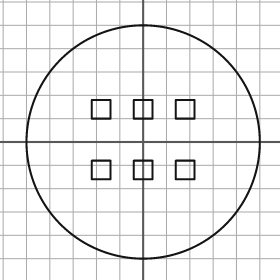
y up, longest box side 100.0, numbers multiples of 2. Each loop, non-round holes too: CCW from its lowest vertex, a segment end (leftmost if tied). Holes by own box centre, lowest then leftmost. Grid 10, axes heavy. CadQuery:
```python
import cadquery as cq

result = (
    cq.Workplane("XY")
    .moveTo(0.0, 0.0)
    .circle(50.0)
    .moveTo(-22.0, -16.0)
    .lineTo(-14.0, -16.0)
    .lineTo(-14.0, -8.0)
    .lineTo(-22.0, -8.0)
    .close()
    .moveTo(-4.0, -16.0)
    .lineTo(4.0, -16.0)
    .lineTo(4.0, -8.0)
    .lineTo(-4.0, -8.0)
    .close()
    .moveTo(14.0, -16.0)
    .lineTo(22.0, -16.0)
    .lineTo(22.0, -8.0)
    .lineTo(14.0, -8.0)
    .close()
    .moveTo(-22.0, 10.0)
    .lineTo(-14.0, 10.0)
    .lineTo(-14.0, 18.0)
    .lineTo(-22.0, 18.0)
    .close()
    .moveTo(-4.0, 10.0)
    .lineTo(4.0, 10.0)
    .lineTo(4.0, 18.0)
    .lineTo(-4.0, 18.0)
    .close()
    .moveTo(14.0, 10.0)
    .lineTo(22.0, 10.0)
    .lineTo(22.0, 18.0)
    .lineTo(14.0, 18.0)
    .close()
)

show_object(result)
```